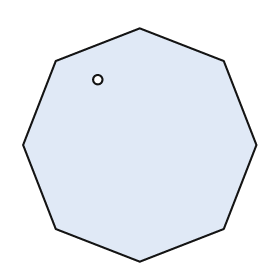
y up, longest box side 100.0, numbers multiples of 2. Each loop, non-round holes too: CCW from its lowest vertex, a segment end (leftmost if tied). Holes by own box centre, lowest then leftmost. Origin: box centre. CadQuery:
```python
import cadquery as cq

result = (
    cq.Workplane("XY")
    .moveTo(0.0, -50.0)
    .lineTo(36.0, -36.0)
    .lineTo(50.0, 0.0)
    .lineTo(36.0, 36.0)
    .lineTo(0.0, 50.0)
    .lineTo(-36.0, 36.0)
    .lineTo(-50.0, 0.0)
    .lineTo(-36.0, -36.0)
    .close()
    .moveTo(-18.0, 28.0)
    .circle(2.0)
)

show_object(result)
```